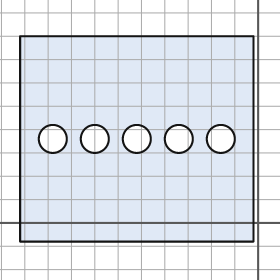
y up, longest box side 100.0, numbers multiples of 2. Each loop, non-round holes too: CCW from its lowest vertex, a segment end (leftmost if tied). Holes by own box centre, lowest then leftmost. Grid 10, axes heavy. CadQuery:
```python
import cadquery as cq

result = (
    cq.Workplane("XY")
    .moveTo(-102.0, -8.0)
    .lineTo(-2.0, -8.0)
    .lineTo(-2.0, 80.0)
    .lineTo(-102.0, 80.0)
    .close()
    .moveTo(-88.0, 36.0)
    .circle(6.0)
    .moveTo(-70.0, 36.0)
    .circle(6.0)
    .moveTo(-52.0, 36.0)
    .circle(6.0)
    .moveTo(-34.0, 36.0)
    .circle(6.0)
    .moveTo(-16.0, 36.0)
    .circle(6.0)
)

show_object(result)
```